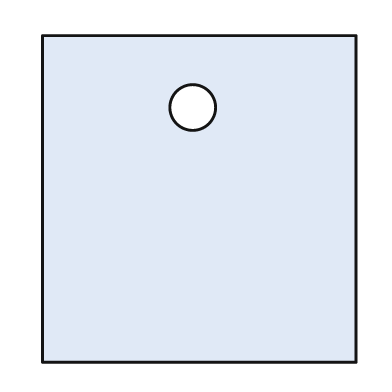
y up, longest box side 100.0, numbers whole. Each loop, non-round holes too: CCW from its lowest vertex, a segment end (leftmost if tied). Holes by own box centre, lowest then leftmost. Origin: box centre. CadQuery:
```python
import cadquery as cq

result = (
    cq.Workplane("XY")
    .moveTo(-48.0, -50.0)
    .lineTo(48.0, -50.0)
    .lineTo(48.0, 50.0)
    .lineTo(-48.0, 50.0)
    .close()
    .moveTo(-2.0, 28.0)
    .circle(7.0)
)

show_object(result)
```